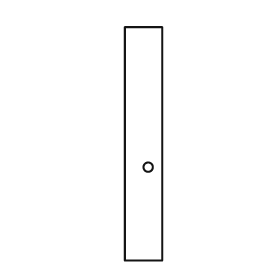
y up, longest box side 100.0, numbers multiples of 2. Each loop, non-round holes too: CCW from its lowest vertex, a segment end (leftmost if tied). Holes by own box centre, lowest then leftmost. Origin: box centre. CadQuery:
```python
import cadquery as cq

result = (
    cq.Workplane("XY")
    .moveTo(-8.0, -50.0)
    .lineTo(8.0, -50.0)
    .lineTo(8.0, 50.0)
    .lineTo(-8.0, 50.0)
    .close()
    .moveTo(2.0, -10.0)
    .circle(2.0)
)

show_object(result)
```